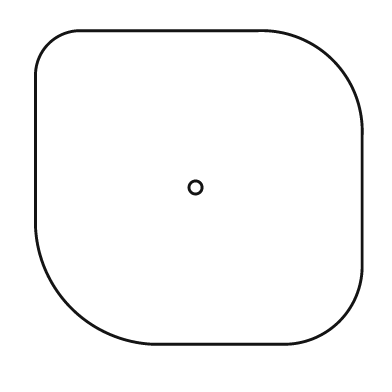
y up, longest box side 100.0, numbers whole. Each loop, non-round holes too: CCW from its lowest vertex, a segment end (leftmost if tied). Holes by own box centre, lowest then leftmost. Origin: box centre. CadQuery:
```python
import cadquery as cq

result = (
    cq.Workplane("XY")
    .moveTo(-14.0, -48.0)
    .lineTo(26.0, -48.0)
    .threePointArc((43.0, -41.0), (50.0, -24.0))
    .lineTo(50.0, 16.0)
    .threePointArc((41.0, 39.0), (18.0, 48.0))
    .lineTo(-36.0, 48.0)
    .threePointArc((-46.0, 44.0), (-50.0, 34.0))
    .lineTo(-50.0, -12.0)
    .threePointArc((-39.0, -37.0), (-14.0, -48.0))
    .close()
    .moveTo(-1.0, 0.0)
    .circle(2.0)
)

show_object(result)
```